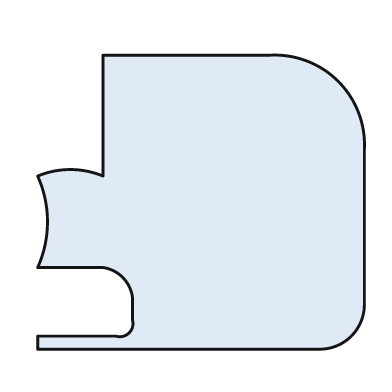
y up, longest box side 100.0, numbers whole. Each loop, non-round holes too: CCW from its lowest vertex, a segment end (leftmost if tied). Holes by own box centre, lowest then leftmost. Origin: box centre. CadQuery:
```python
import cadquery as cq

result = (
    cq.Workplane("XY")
    .moveTo(-50.0, -45.0)
    .lineTo(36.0, -45.0)
    .threePointArc((46.0, -41.0), (50.0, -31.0))
    .lineTo(50.0, 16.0)
    .threePointArc((42.0, 37.0), (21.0, 45.0))
    .lineTo(-30.0, 45.0)
    .lineTo(-30.0, 8.0)
    .threePointArc((-40.0, 10.0), (-50.0, 8.0))
    .threePointArc((-47.0, -6.0), (-50.0, -20.0))
    .lineTo(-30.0, -20.0)
    .threePointArc((-24.0, -23.0), (-21.0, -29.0))
    .lineTo(-21.0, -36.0)
    .threePointArc((-22.0, -40.0), (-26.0, -41.0))
    .lineTo(-50.0, -41.0)
    .close()
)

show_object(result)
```